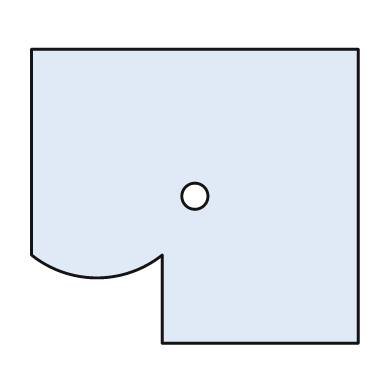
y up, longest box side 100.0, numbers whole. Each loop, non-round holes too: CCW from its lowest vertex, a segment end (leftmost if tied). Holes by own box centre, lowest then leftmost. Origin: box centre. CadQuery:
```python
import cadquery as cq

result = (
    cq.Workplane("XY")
    .moveTo(-10.0, -45.0)
    .lineTo(50.0, -45.0)
    .lineTo(50.0, 45.0)
    .lineTo(-50.0, 45.0)
    .lineTo(-50.0, -18.0)
    .threePointArc((-30.0, -25.0), (-10.0, -18.0))
    .close()
    .moveTo(0.0, 0.0)
    .circle(4.0)
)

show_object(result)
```